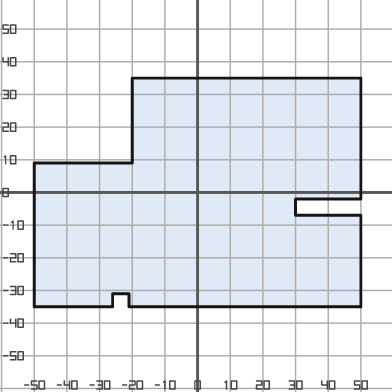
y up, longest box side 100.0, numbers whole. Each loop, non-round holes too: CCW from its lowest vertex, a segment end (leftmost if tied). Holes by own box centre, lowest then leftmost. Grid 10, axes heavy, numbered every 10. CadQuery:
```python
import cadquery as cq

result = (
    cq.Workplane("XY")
    .moveTo(-50.0, -35.0)
    .lineTo(-26.0, -35.0)
    .lineTo(-26.0, -31.0)
    .lineTo(-21.0, -31.0)
    .lineTo(-21.0, -35.0)
    .lineTo(50.0, -35.0)
    .lineTo(50.0, -7.0)
    .lineTo(30.0, -7.0)
    .lineTo(30.0, -2.0)
    .lineTo(50.0, -2.0)
    .lineTo(50.0, 35.0)
    .lineTo(-20.0, 35.0)
    .lineTo(-20.0, 9.0)
    .lineTo(-50.0, 9.0)
    .close()
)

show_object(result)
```